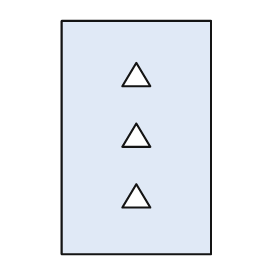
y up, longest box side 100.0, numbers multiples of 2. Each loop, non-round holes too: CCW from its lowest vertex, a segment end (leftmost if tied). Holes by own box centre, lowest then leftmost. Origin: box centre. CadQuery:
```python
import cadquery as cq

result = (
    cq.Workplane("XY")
    .moveTo(-32.0, -50.0)
    .lineTo(32.0, -50.0)
    .lineTo(32.0, 50.0)
    .lineTo(-32.0, 50.0)
    .close()
    .moveTo(-6.0, -30.0)
    .lineTo(6.0, -30.0)
    .lineTo(0.0, -20.0)
    .close()
    .moveTo(-6.0, -4.0)
    .lineTo(6.0, -4.0)
    .lineTo(0.0, 6.0)
    .close()
    .moveTo(-6.0, 22.0)
    .lineTo(6.0, 22.0)
    .lineTo(0.0, 32.0)
    .close()
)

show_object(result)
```